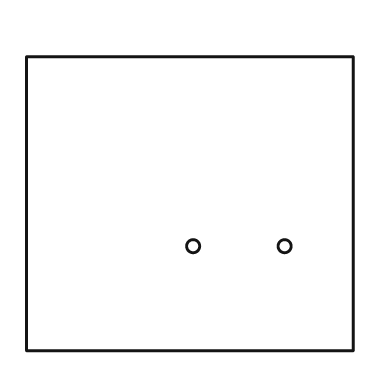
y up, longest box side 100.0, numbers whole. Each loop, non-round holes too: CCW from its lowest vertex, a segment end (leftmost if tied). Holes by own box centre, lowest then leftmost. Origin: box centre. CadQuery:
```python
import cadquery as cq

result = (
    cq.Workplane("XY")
    .moveTo(-50.0, -45.0)
    .lineTo(50.0, -45.0)
    .lineTo(50.0, 45.0)
    .lineTo(-50.0, 45.0)
    .close()
    .moveTo(1.0, -13.0)
    .circle(2.0)
    .moveTo(29.0, -13.0)
    .circle(2.0)
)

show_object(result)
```